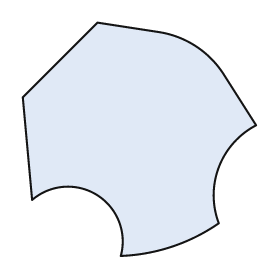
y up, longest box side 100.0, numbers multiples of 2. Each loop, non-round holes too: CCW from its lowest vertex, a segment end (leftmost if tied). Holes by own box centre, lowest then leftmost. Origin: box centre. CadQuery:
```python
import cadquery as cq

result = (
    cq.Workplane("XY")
    .moveTo(-8.0, -50.0)
    .threePointArc((14.0, -46.0), (34.0, -36.0))
    .threePointArc((34.0, -12.0), (50.0, 6.0))
    .lineTo(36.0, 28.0)
    .threePointArc((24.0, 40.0), (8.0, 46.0))
    .lineTo(-18.0, 50.0)
    .lineTo(-50.0, 18.0)
    .lineTo(-46.0, -26.0)
    .threePointArc((-18.0, -24.0), (-8.0, -50.0))
    .close()
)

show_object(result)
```